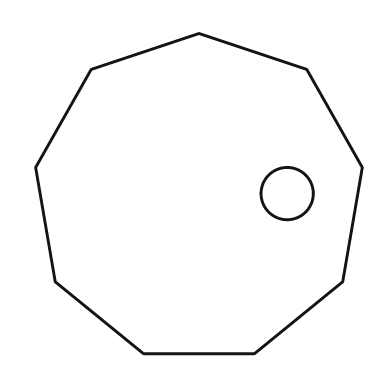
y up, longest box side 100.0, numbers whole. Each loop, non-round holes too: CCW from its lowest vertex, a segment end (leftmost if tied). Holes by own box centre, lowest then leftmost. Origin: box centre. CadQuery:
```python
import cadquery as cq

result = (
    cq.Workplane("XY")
    .moveTo(-17.0, -49.0)
    .lineTo(17.0, -49.0)
    .lineTo(44.0, -27.0)
    .lineTo(50.0, 8.0)
    .lineTo(33.0, 38.0)
    .lineTo(0.0, 49.0)
    .lineTo(-33.0, 38.0)
    .lineTo(-50.0, 8.0)
    .lineTo(-44.0, -27.0)
    .close()
    .moveTo(27.0, 0.0)
    .circle(8.0)
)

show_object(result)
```